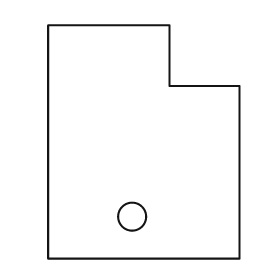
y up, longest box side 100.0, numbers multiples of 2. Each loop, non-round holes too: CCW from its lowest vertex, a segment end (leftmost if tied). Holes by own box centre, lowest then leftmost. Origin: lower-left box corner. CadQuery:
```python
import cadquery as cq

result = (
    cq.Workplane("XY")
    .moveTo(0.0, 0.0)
    .lineTo(82.0, 0.0)
    .lineTo(82.0, 74.0)
    .lineTo(52.0, 74.0)
    .lineTo(52.0, 100.0)
    .lineTo(0.0, 100.0)
    .close()
    .moveTo(36.0, 18.0)
    .circle(6.0)
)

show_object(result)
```